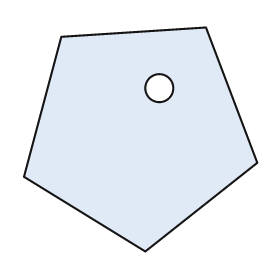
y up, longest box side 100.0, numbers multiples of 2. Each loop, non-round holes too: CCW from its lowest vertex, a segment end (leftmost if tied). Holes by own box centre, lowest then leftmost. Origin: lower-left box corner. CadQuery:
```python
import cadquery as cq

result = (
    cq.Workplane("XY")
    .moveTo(52.0, 0.0)
    .lineTo(100.0, 38.0)
    .lineTo(78.0, 96.0)
    .lineTo(16.0, 92.0)
    .lineTo(0.0, 32.0)
    .close()
    .moveTo(58.0, 70.0)
    .circle(6.0)
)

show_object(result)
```